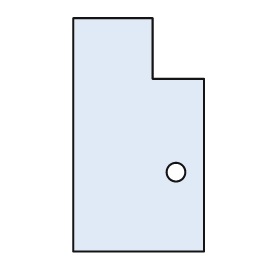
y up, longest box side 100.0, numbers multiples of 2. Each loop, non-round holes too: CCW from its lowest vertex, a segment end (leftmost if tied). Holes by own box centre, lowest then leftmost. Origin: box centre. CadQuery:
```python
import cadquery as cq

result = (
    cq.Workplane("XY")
    .moveTo(-28.0, -50.0)
    .lineTo(28.0, -50.0)
    .lineTo(28.0, 24.0)
    .lineTo(6.0, 24.0)
    .lineTo(6.0, 50.0)
    .lineTo(-28.0, 50.0)
    .close()
    .moveTo(16.0, -16.0)
    .circle(4.0)
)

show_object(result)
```